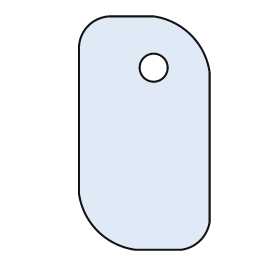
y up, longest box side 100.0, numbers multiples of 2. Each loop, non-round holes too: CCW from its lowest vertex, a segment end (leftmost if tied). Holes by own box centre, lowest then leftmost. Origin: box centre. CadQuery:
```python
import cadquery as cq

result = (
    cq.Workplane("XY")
    .moveTo(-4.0, -50.0)
    .lineTo(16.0, -50.0)
    .threePointArc((24.0, -46.0), (28.0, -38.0))
    .lineTo(28.0, 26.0)
    .threePointArc((20.0, 42.0), (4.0, 50.0))
    .lineTo(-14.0, 50.0)
    .threePointArc((-24.0, 46.0), (-28.0, 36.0))
    .lineTo(-28.0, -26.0)
    .threePointArc((-20.0, -42.0), (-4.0, -50.0))
    .close()
    .moveTo(4.0, 28.0)
    .circle(6.0)
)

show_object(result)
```